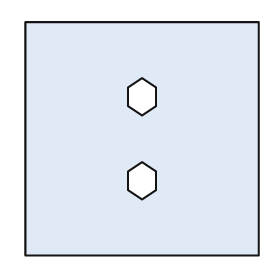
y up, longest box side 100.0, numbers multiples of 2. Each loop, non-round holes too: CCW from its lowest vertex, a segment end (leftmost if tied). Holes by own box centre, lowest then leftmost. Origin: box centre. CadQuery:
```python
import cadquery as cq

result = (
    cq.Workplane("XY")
    .moveTo(-50.0, -50.0)
    .lineTo(50.0, -50.0)
    .lineTo(50.0, 50.0)
    .lineTo(-50.0, 50.0)
    .close()
    .moveTo(0.0, -26.0)
    .lineTo(6.0, -22.0)
    .lineTo(6.0, -14.0)
    .lineTo(0.0, -10.0)
    .lineTo(-6.0, -14.0)
    .lineTo(-6.0, -22.0)
    .close()
    .moveTo(0.0, 10.0)
    .lineTo(6.0, 14.0)
    .lineTo(6.0, 22.0)
    .lineTo(0.0, 26.0)
    .lineTo(-6.0, 22.0)
    .lineTo(-6.0, 14.0)
    .close()
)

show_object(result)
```